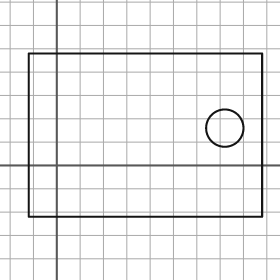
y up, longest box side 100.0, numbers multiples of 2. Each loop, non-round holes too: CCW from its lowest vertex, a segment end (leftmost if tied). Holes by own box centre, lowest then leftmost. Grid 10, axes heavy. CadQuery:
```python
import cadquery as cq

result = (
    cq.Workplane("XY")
    .moveTo(-12.0, -22.0)
    .lineTo(88.0, -22.0)
    .lineTo(88.0, 48.0)
    .lineTo(-12.0, 48.0)
    .close()
    .moveTo(72.0, 16.0)
    .circle(8.0)
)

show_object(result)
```